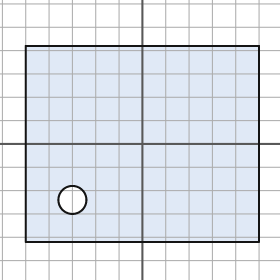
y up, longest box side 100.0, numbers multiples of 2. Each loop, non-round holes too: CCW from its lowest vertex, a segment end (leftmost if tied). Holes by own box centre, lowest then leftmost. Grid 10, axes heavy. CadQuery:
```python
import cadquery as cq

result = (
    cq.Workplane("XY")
    .moveTo(-50.0, -42.0)
    .lineTo(50.0, -42.0)
    .lineTo(50.0, 42.0)
    .lineTo(-50.0, 42.0)
    .close()
    .moveTo(-30.0, -24.0)
    .circle(6.0)
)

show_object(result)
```